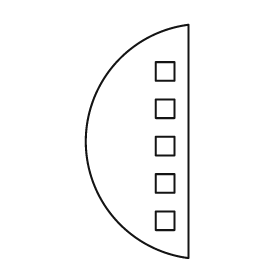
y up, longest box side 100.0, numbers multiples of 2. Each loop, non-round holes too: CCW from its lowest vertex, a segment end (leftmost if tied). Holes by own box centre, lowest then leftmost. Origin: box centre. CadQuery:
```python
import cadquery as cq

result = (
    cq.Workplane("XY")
    .moveTo(22.0, -50.0)
    .lineTo(22.0, 50.0)
    .threePointArc((-22.0, 0.0), (22.0, -50.0))
    .close()
    .moveTo(8.0, -38.0)
    .lineTo(16.0, -38.0)
    .lineTo(16.0, -30.0)
    .lineTo(8.0, -30.0)
    .close()
    .moveTo(8.0, -22.0)
    .lineTo(16.0, -22.0)
    .lineTo(16.0, -14.0)
    .lineTo(8.0, -14.0)
    .close()
    .moveTo(8.0, -6.0)
    .lineTo(16.0, -6.0)
    .lineTo(16.0, 2.0)
    .lineTo(8.0, 2.0)
    .close()
    .moveTo(8.0, 10.0)
    .lineTo(16.0, 10.0)
    .lineTo(16.0, 18.0)
    .lineTo(8.0, 18.0)
    .close()
    .moveTo(8.0, 26.0)
    .lineTo(16.0, 26.0)
    .lineTo(16.0, 34.0)
    .lineTo(8.0, 34.0)
    .close()
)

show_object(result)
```